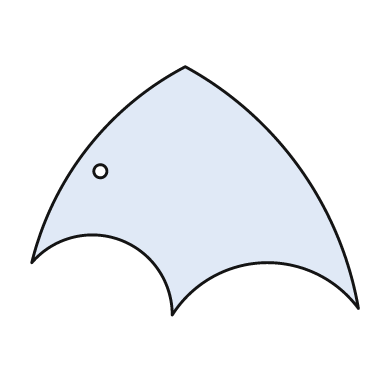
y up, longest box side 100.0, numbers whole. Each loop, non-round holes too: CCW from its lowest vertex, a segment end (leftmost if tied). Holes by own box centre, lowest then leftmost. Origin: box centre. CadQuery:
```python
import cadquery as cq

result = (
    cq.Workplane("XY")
    .moveTo(-7.0, -38.0)
    .threePointArc((21.0, -22.0), (50.0, -36.0))
    .threePointArc((32.0, 7.0), (-3.0, 38.0))
    .threePointArc((-33.0, 13.0), (-50.0, -22.0))
    .threePointArc((-23.0, -15.0), (-7.0, -38.0))
    .close()
    .moveTo(-29.0, 6.0)
    .circle(2.0)
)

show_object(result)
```